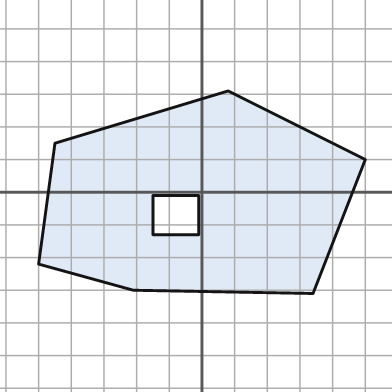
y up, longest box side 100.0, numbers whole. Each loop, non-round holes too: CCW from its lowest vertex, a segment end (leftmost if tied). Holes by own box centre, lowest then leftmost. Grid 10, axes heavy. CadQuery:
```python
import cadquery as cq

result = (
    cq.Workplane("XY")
    .moveTo(34.0, -31.0)
    .lineTo(50.0, 10.0)
    .lineTo(8.0, 31.0)
    .lineTo(-45.0, 15.0)
    .lineTo(-50.0, -22.0)
    .lineTo(-21.0, -30.0)
    .close()
    .moveTo(-15.0, -13.0)
    .lineTo(-1.0, -13.0)
    .lineTo(-1.0, -1.0)
    .lineTo(-15.0, -1.0)
    .close()
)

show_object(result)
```